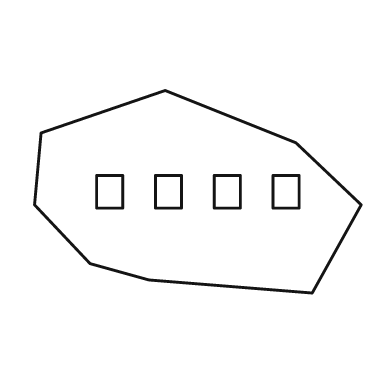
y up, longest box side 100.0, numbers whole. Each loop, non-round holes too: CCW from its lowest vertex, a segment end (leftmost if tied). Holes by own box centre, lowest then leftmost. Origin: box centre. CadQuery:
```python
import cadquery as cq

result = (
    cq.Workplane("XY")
    .moveTo(35.0, -31.0)
    .lineTo(50.0, -4.0)
    .lineTo(30.0, 15.0)
    .lineTo(-10.0, 31.0)
    .lineTo(-48.0, 18.0)
    .lineTo(-50.0, -4.0)
    .lineTo(-33.0, -22.0)
    .lineTo(-15.0, -27.0)
    .close()
    .moveTo(-31.0, -5.0)
    .lineTo(-23.0, -5.0)
    .lineTo(-23.0, 5.0)
    .lineTo(-31.0, 5.0)
    .close()
    .moveTo(-13.0, -5.0)
    .lineTo(-5.0, -5.0)
    .lineTo(-5.0, 5.0)
    .lineTo(-13.0, 5.0)
    .close()
    .moveTo(5.0, -5.0)
    .lineTo(13.0, -5.0)
    .lineTo(13.0, 5.0)
    .lineTo(5.0, 5.0)
    .close()
    .moveTo(23.0, -5.0)
    .lineTo(31.0, -5.0)
    .lineTo(31.0, 5.0)
    .lineTo(23.0, 5.0)
    .close()
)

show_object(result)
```